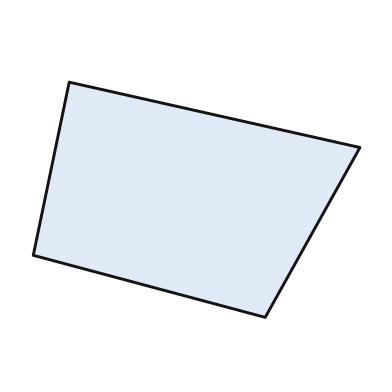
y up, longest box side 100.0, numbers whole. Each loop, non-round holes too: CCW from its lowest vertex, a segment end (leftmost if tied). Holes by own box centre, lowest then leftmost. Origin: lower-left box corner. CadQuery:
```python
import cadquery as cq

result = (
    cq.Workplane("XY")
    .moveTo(71.0, 0.0)
    .lineTo(100.0, 52.0)
    .lineTo(11.0, 72.0)
    .lineTo(0.0, 19.0)
    .close()
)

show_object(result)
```